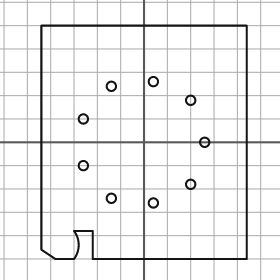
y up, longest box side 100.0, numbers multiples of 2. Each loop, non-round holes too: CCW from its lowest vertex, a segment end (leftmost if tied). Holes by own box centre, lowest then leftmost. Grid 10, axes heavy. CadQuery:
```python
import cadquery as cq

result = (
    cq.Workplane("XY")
    .moveTo(-38.0, -50.0)
    .lineTo(-30.0, -50.0)
    .threePointArc((-28.0, -44.0), (-30.0, -38.0))
    .lineTo(-22.0, -38.0)
    .lineTo(-22.0, -50.0)
    .lineTo(44.0, -50.0)
    .lineTo(44.0, 50.0)
    .lineTo(-44.0, 50.0)
    .lineTo(-44.0, -46.0)
    .close()
    .moveTo(4.0, -26.0)
    .circle(2.0)
    .moveTo(-14.0, -24.0)
    .circle(2.0)
    .moveTo(20.0, -18.0)
    .circle(2.0)
    .moveTo(-26.0, -10.0)
    .circle(2.0)
    .moveTo(26.0, 0.0)
    .circle(2.0)
    .moveTo(-26.0, 10.0)
    .circle(2.0)
    .moveTo(20.0, 18.0)
    .circle(2.0)
    .moveTo(-14.0, 24.0)
    .circle(2.0)
    .moveTo(4.0, 26.0)
    .circle(2.0)
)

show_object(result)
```